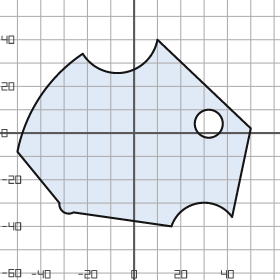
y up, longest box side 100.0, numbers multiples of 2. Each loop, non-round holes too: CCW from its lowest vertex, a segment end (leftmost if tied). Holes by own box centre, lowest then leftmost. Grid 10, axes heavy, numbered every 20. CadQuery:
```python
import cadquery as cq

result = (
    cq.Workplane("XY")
    .moveTo(16.0, -40.0)
    .threePointArc((28.0, -30.0), (42.0, -36.0))
    .lineTo(50.0, 2.0)
    .lineTo(10.0, 40.0)
    .threePointArc((-4.0, 26.0), (-22.0, 34.0))
    .threePointArc((-40.0, 16.0), (-50.0, -8.0))
    .lineTo(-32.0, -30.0)
    .threePointArc((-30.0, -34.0), (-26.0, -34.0))
    .close()
    .moveTo(32.0, 4.0)
    .circle(6.0)
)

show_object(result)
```